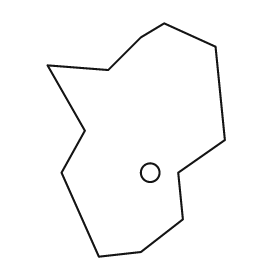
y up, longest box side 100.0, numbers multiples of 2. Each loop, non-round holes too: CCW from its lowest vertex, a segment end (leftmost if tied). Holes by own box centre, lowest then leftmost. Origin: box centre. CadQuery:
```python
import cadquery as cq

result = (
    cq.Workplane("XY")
    .moveTo(-16.0, -50.0)
    .lineTo(2.0, -48.0)
    .lineTo(20.0, -34.0)
    .lineTo(18.0, -14.0)
    .lineTo(38.0, 0.0)
    .lineTo(34.0, 40.0)
    .lineTo(12.0, 50.0)
    .lineTo(2.0, 44.0)
    .lineTo(-12.0, 30.0)
    .lineTo(-38.0, 32.0)
    .lineTo(-22.0, 4.0)
    .lineTo(-32.0, -14.0)
    .close()
    .moveTo(6.0, -14.0)
    .circle(4.0)
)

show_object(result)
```